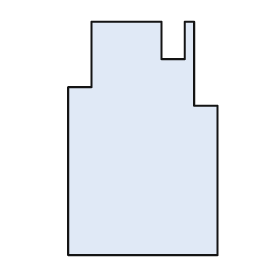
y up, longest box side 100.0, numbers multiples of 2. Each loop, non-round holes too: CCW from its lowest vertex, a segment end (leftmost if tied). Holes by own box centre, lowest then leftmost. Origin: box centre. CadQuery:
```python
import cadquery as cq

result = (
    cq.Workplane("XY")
    .moveTo(-32.0, -50.0)
    .lineTo(32.0, -50.0)
    .lineTo(32.0, 14.0)
    .lineTo(22.0, 14.0)
    .lineTo(22.0, 50.0)
    .lineTo(18.0, 50.0)
    .lineTo(18.0, 34.0)
    .lineTo(8.0, 34.0)
    .lineTo(8.0, 50.0)
    .lineTo(-22.0, 50.0)
    .lineTo(-22.0, 22.0)
    .lineTo(-32.0, 22.0)
    .close()
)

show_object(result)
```